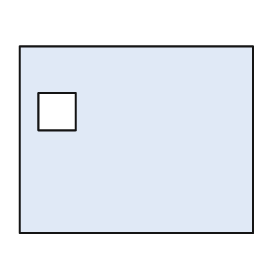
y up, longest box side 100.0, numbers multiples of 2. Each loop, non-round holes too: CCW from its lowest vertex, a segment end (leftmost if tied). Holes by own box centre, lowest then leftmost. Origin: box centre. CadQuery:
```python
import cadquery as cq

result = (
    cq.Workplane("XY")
    .moveTo(-50.0, -40.0)
    .lineTo(50.0, -40.0)
    .lineTo(50.0, 40.0)
    .lineTo(-50.0, 40.0)
    .close()
    .moveTo(-42.0, 4.0)
    .lineTo(-26.0, 4.0)
    .lineTo(-26.0, 20.0)
    .lineTo(-42.0, 20.0)
    .close()
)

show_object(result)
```